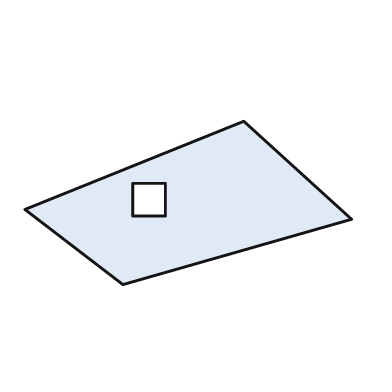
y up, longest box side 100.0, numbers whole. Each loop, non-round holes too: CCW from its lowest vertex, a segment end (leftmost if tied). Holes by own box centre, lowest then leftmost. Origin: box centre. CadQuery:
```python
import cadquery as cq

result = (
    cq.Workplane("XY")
    .moveTo(-20.0, -25.0)
    .lineTo(50.0, -5.0)
    .lineTo(17.0, 25.0)
    .lineTo(-50.0, -2.0)
    .close()
    .moveTo(-17.0, -4.0)
    .lineTo(-7.0, -4.0)
    .lineTo(-7.0, 6.0)
    .lineTo(-17.0, 6.0)
    .close()
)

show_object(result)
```